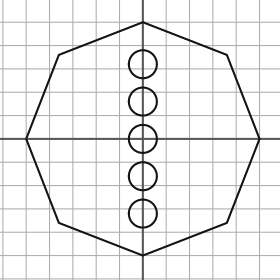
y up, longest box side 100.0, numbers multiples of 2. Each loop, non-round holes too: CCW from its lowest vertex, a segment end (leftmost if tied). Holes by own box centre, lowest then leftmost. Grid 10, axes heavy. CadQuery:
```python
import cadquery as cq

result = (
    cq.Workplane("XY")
    .moveTo(0.0, -50.0)
    .lineTo(36.0, -36.0)
    .lineTo(50.0, 0.0)
    .lineTo(36.0, 36.0)
    .lineTo(0.0, 50.0)
    .lineTo(-36.0, 36.0)
    .lineTo(-50.0, 0.0)
    .lineTo(-36.0, -36.0)
    .close()
    .moveTo(0.0, -32.0)
    .circle(6.0)
    .moveTo(0.0, -16.0)
    .circle(6.0)
    .moveTo(0.0, 0.0)
    .circle(6.0)
    .moveTo(0.0, 16.0)
    .circle(6.0)
    .moveTo(0.0, 32.0)
    .circle(6.0)
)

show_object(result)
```